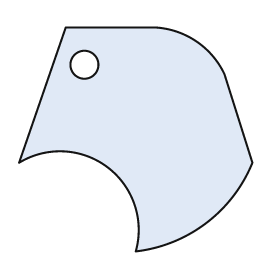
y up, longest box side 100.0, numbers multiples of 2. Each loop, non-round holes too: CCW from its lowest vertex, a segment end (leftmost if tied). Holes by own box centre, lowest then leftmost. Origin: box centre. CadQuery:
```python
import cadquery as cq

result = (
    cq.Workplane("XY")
    .moveTo(0.0, -48.0)
    .threePointArc((30.0, -36.0), (50.0, -10.0))
    .lineTo(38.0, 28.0)
    .threePointArc((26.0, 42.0), (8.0, 48.0))
    .lineTo(-30.0, 48.0)
    .lineTo(-50.0, -10.0)
    .threePointArc((-12.0, -12.0), (0.0, -48.0))
    .close()
    .moveTo(-22.0, 32.0)
    .circle(6.0)
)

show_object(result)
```